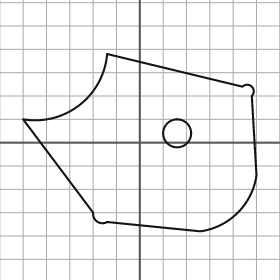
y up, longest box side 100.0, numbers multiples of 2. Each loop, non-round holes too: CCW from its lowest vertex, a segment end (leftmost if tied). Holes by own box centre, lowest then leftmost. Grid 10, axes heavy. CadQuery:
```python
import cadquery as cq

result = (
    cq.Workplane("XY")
    .moveTo(26.0, -38.0)
    .threePointArc((42.0, -30.0), (50.0, -14.0))
    .lineTo(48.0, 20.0)
    .threePointArc((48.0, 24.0), (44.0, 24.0))
    .lineTo(-14.0, 38.0)
    .threePointArc((-26.0, 16.0), (-50.0, 10.0))
    .lineTo(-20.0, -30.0)
    .threePointArc((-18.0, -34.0), (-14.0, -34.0))
    .close()
    .moveTo(16.0, 4.0)
    .circle(6.0)
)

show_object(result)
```